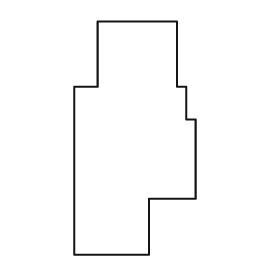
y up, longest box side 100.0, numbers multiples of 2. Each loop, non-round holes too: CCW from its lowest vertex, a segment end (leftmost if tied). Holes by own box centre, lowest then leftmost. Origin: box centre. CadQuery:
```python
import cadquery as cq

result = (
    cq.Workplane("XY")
    .moveTo(-26.0, -50.0)
    .lineTo(6.0, -50.0)
    .lineTo(6.0, -26.0)
    .lineTo(26.0, -26.0)
    .lineTo(26.0, 8.0)
    .lineTo(22.0, 8.0)
    .lineTo(22.0, 22.0)
    .lineTo(18.0, 22.0)
    .lineTo(18.0, 50.0)
    .lineTo(-16.0, 50.0)
    .lineTo(-16.0, 22.0)
    .lineTo(-26.0, 22.0)
    .close()
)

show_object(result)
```